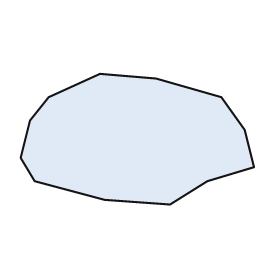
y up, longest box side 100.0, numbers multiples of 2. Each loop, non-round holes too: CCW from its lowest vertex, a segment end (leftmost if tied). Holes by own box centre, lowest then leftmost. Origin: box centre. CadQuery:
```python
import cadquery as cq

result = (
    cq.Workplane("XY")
    .moveTo(14.0, -28.0)
    .lineTo(30.0, -18.0)
    .lineTo(50.0, -12.0)
    .lineTo(46.0, 4.0)
    .lineTo(36.0, 18.0)
    .lineTo(8.0, 26.0)
    .lineTo(-16.0, 28.0)
    .lineTo(-38.0, 18.0)
    .lineTo(-46.0, 8.0)
    .lineTo(-50.0, -8.0)
    .lineTo(-44.0, -18.0)
    .lineTo(-14.0, -26.0)
    .close()
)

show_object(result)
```